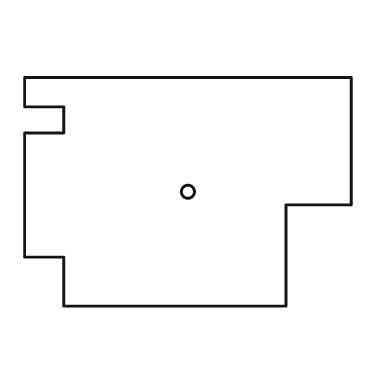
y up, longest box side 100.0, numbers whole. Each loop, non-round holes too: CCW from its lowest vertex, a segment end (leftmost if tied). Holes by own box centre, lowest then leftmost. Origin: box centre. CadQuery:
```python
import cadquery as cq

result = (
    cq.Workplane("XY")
    .moveTo(-38.0, -35.0)
    .lineTo(30.0, -35.0)
    .lineTo(30.0, -4.0)
    .lineTo(50.0, -4.0)
    .lineTo(50.0, 35.0)
    .lineTo(-50.0, 35.0)
    .lineTo(-50.0, 26.0)
    .lineTo(-38.0, 26.0)
    .lineTo(-38.0, 18.0)
    .lineTo(-50.0, 18.0)
    .lineTo(-50.0, -20.0)
    .lineTo(-38.0, -20.0)
    .close()
    .moveTo(0.0, 0.0)
    .circle(2.0)
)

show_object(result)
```